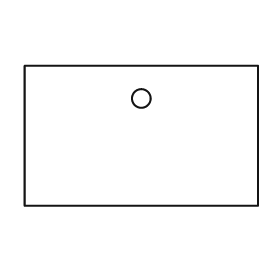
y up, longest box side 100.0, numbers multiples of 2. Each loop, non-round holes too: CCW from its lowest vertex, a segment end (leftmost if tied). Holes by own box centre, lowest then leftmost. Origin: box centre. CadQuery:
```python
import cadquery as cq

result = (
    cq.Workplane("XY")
    .moveTo(-50.0, -30.0)
    .lineTo(50.0, -30.0)
    .lineTo(50.0, 30.0)
    .lineTo(-50.0, 30.0)
    .close()
    .moveTo(0.0, 16.0)
    .circle(4.0)
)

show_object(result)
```